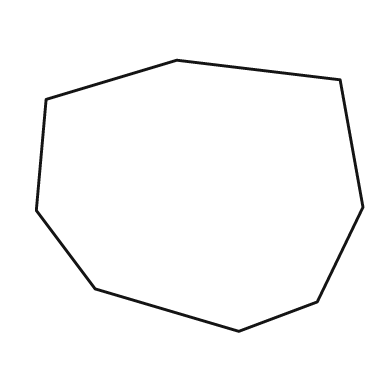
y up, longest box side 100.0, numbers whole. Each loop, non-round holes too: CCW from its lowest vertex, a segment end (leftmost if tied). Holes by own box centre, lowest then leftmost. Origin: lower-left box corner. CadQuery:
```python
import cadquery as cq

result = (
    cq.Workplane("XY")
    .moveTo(62.0, 0.0)
    .lineTo(86.0, 9.0)
    .lineTo(100.0, 38.0)
    .lineTo(93.0, 77.0)
    .lineTo(43.0, 83.0)
    .lineTo(3.0, 71.0)
    .lineTo(0.0, 37.0)
    .lineTo(18.0, 13.0)
    .close()
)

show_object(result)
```